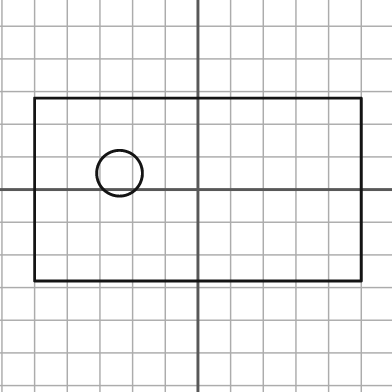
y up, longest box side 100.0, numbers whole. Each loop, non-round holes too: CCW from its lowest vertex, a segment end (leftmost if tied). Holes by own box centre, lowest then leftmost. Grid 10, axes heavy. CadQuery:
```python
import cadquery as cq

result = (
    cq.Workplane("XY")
    .moveTo(-50.0, -28.0)
    .lineTo(50.0, -28.0)
    .lineTo(50.0, 28.0)
    .lineTo(-50.0, 28.0)
    .close()
    .moveTo(-24.0, 5.0)
    .circle(7.0)
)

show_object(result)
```